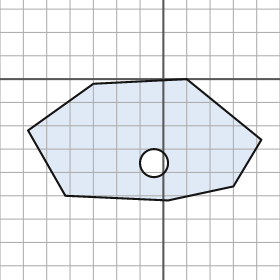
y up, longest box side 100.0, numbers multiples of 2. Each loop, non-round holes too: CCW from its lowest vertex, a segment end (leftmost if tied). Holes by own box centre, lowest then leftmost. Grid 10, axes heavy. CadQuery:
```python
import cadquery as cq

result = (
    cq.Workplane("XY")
    .moveTo(2.0, -52.0)
    .lineTo(30.0, -46.0)
    .lineTo(42.0, -26.0)
    .lineTo(10.0, 0.0)
    .lineTo(-30.0, -2.0)
    .lineTo(-58.0, -22.0)
    .lineTo(-42.0, -50.0)
    .close()
    .moveTo(-4.0, -36.0)
    .circle(6.0)
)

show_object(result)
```